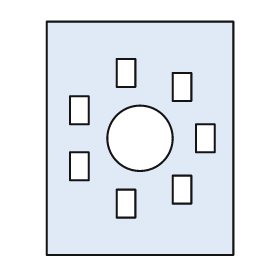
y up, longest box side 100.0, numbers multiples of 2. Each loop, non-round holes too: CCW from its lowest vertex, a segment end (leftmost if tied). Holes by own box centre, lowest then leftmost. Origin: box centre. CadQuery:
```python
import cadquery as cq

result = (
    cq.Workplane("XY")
    .moveTo(-40.0, -50.0)
    .lineTo(40.0, -50.0)
    .lineTo(40.0, 50.0)
    .lineTo(-40.0, 50.0)
    .close()
    .moveTo(-10.0, -34.0)
    .lineTo(-2.0, -34.0)
    .lineTo(-2.0, -22.0)
    .lineTo(-10.0, -22.0)
    .close()
    .moveTo(14.0, -28.0)
    .lineTo(22.0, -28.0)
    .lineTo(22.0, -16.0)
    .lineTo(14.0, -16.0)
    .close()
    .moveTo(-30.0, -18.0)
    .lineTo(-22.0, -18.0)
    .lineTo(-22.0, -6.0)
    .lineTo(-30.0, -6.0)
    .close()
    .moveTo(0.0, 0.0)
    .circle(14.0)
    .moveTo(24.0, -6.0)
    .lineTo(32.0, -6.0)
    .lineTo(32.0, 6.0)
    .lineTo(24.0, 6.0)
    .close()
    .moveTo(-30.0, 6.0)
    .lineTo(-22.0, 6.0)
    .lineTo(-22.0, 18.0)
    .lineTo(-30.0, 18.0)
    .close()
    .moveTo(14.0, 16.0)
    .lineTo(22.0, 16.0)
    .lineTo(22.0, 28.0)
    .lineTo(14.0, 28.0)
    .close()
    .moveTo(-10.0, 22.0)
    .lineTo(-2.0, 22.0)
    .lineTo(-2.0, 34.0)
    .lineTo(-10.0, 34.0)
    .close()
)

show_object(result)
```